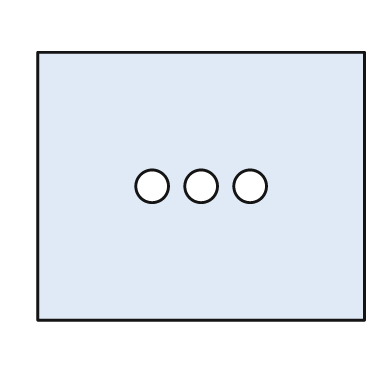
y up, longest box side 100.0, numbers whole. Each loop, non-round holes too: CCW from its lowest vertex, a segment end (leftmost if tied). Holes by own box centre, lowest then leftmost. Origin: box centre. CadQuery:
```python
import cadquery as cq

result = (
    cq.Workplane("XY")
    .moveTo(-50.0, -41.0)
    .lineTo(50.0, -41.0)
    .lineTo(50.0, 41.0)
    .lineTo(-50.0, 41.0)
    .close()
    .moveTo(-15.0, 0.0)
    .circle(5.0)
    .moveTo(0.0, 0.0)
    .circle(5.0)
    .moveTo(15.0, 0.0)
    .circle(5.0)
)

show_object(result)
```